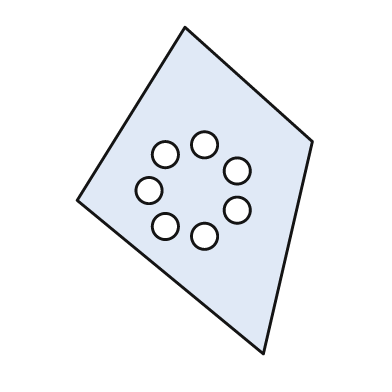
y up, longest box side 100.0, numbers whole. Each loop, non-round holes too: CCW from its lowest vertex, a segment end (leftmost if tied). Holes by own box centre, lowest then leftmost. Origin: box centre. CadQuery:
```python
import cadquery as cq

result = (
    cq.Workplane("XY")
    .moveTo(21.0, -50.0)
    .lineTo(36.0, 15.0)
    .lineTo(-3.0, 50.0)
    .lineTo(-36.0, -3.0)
    .close()
    .moveTo(3.0, -14.0)
    .circle(4.0)
    .moveTo(-9.0, -11.0)
    .circle(4.0)
    .moveTo(13.0, -6.0)
    .circle(4.0)
    .moveTo(-14.0, 0.0)
    .circle(4.0)
    .moveTo(13.0, 6.0)
    .circle(4.0)
    .moveTo(-9.0, 11.0)
    .circle(4.0)
    .moveTo(3.0, 14.0)
    .circle(4.0)
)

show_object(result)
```